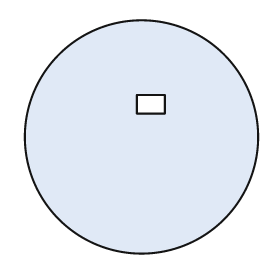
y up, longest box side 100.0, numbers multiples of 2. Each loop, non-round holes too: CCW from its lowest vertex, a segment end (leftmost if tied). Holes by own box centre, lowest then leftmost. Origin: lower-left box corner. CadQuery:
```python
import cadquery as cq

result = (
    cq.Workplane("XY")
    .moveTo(50.0, 50.0)
    .circle(50.0)
    .moveTo(48.0, 60.0)
    .lineTo(60.0, 60.0)
    .lineTo(60.0, 68.0)
    .lineTo(48.0, 68.0)
    .close()
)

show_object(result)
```